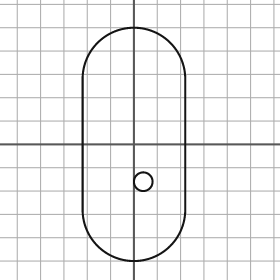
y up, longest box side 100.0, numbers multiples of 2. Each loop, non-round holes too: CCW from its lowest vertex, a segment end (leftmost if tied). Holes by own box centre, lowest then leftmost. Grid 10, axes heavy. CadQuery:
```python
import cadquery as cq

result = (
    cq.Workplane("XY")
    .moveTo(-22.0, -28.0)
    .threePointArc((0.0, -50.0), (22.0, -28.0))
    .lineTo(22.0, 28.0)
    .threePointArc((0.0, 50.0), (-22.0, 28.0))
    .close()
    .moveTo(4.0, -16.0)
    .circle(4.0)
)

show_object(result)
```